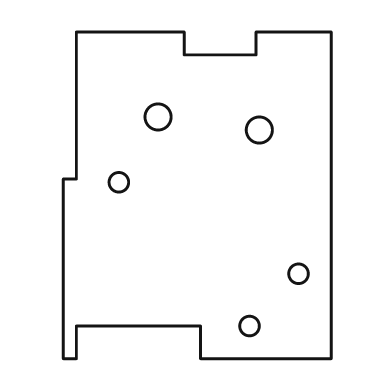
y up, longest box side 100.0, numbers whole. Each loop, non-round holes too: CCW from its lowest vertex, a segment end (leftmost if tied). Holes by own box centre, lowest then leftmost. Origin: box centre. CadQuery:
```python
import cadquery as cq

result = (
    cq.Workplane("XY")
    .moveTo(-41.0, -50.0)
    .lineTo(-37.0, -50.0)
    .lineTo(-37.0, -40.0)
    .lineTo(1.0, -40.0)
    .lineTo(1.0, -50.0)
    .lineTo(41.0, -50.0)
    .lineTo(41.0, 50.0)
    .lineTo(18.0, 50.0)
    .lineTo(18.0, 43.0)
    .lineTo(-4.0, 43.0)
    .lineTo(-4.0, 50.0)
    .lineTo(-37.0, 50.0)
    .lineTo(-37.0, 5.0)
    .lineTo(-41.0, 5.0)
    .close()
    .moveTo(16.0, -40.0)
    .circle(3.0)
    .moveTo(31.0, -24.0)
    .circle(3.0)
    .moveTo(-24.0, 4.0)
    .circle(3.0)
    .moveTo(19.0, 20.0)
    .circle(4.0)
    .moveTo(-12.0, 24.0)
    .circle(4.0)
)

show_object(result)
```